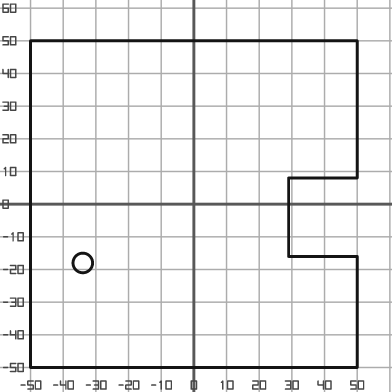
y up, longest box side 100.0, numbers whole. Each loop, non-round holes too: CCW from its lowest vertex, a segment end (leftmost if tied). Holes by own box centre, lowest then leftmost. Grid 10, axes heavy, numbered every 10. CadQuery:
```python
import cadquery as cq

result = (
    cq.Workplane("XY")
    .moveTo(-50.0, -50.0)
    .lineTo(50.0, -50.0)
    .lineTo(50.0, -16.0)
    .lineTo(29.0, -16.0)
    .lineTo(29.0, 8.0)
    .lineTo(50.0, 8.0)
    .lineTo(50.0, 50.0)
    .lineTo(-50.0, 50.0)
    .close()
    .moveTo(-34.0, -18.0)
    .circle(3.0)
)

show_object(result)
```